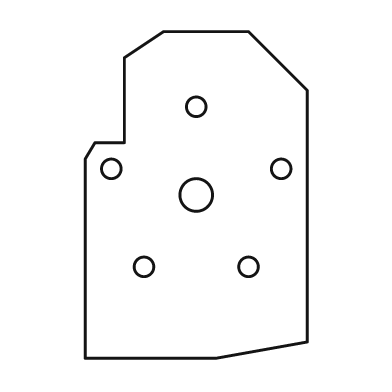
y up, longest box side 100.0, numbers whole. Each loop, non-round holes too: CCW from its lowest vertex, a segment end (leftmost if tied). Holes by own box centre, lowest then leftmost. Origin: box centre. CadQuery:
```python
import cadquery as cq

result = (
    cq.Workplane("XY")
    .moveTo(-34.0, -50.0)
    .lineTo(6.0, -50.0)
    .lineTo(34.0, -45.0)
    .lineTo(34.0, 32.0)
    .lineTo(16.0, 50.0)
    .lineTo(-10.0, 50.0)
    .lineTo(-22.0, 42.0)
    .lineTo(-22.0, 16.0)
    .lineTo(-31.0, 16.0)
    .lineTo(-34.0, 11.0)
    .close()
    .moveTo(-16.0, -22.0)
    .circle(3.0)
    .moveTo(16.0, -22.0)
    .circle(3.0)
    .moveTo(0.0, 0.0)
    .circle(5.0)
    .moveTo(-26.0, 8.0)
    .circle(3.0)
    .moveTo(26.0, 8.0)
    .circle(3.0)
    .moveTo(0.0, 27.0)
    .circle(3.0)
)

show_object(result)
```